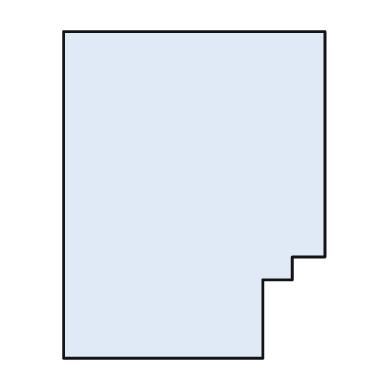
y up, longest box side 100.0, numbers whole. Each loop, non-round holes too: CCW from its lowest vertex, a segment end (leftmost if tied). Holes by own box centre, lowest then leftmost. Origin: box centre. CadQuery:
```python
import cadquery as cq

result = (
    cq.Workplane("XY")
    .moveTo(-40.0, -50.0)
    .lineTo(21.0, -50.0)
    .lineTo(21.0, -26.0)
    .lineTo(30.0, -26.0)
    .lineTo(30.0, -19.0)
    .lineTo(40.0, -19.0)
    .lineTo(40.0, 50.0)
    .lineTo(-40.0, 50.0)
    .close()
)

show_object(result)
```